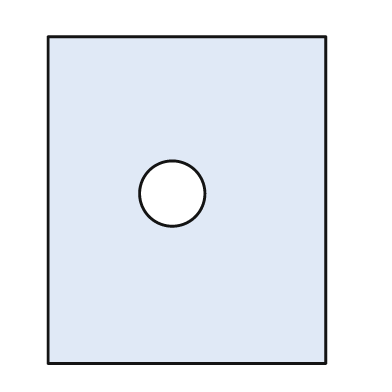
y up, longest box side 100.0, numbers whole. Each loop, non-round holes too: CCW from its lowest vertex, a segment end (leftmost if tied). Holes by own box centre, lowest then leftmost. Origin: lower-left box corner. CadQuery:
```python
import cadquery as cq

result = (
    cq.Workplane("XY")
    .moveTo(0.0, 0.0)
    .lineTo(85.0, 0.0)
    .lineTo(85.0, 100.0)
    .lineTo(0.0, 100.0)
    .close()
    .moveTo(38.0, 52.0)
    .circle(10.0)
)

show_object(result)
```